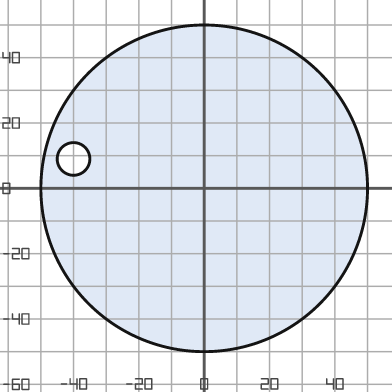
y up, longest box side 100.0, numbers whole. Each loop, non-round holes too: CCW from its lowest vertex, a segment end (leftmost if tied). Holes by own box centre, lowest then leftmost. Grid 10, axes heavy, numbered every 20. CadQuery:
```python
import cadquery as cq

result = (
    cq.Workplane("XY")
    .moveTo(0.0, 0.0)
    .circle(50.0)
    .moveTo(-40.0, 9.0)
    .circle(5.0)
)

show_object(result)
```